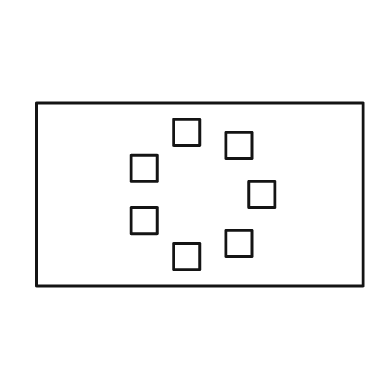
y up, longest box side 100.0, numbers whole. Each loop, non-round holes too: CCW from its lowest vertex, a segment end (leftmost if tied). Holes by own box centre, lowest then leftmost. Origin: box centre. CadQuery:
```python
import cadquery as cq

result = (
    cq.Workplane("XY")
    .moveTo(-50.0, -28.0)
    .lineTo(50.0, -28.0)
    .lineTo(50.0, 28.0)
    .lineTo(-50.0, 28.0)
    .close()
    .moveTo(-8.0, -23.0)
    .lineTo(0.0, -23.0)
    .lineTo(0.0, -15.0)
    .lineTo(-8.0, -15.0)
    .close()
    .moveTo(8.0, -19.0)
    .lineTo(16.0, -19.0)
    .lineTo(16.0, -11.0)
    .lineTo(8.0, -11.0)
    .close()
    .moveTo(-21.0, -12.0)
    .lineTo(-13.0, -12.0)
    .lineTo(-13.0, -4.0)
    .lineTo(-21.0, -4.0)
    .close()
    .moveTo(15.0, -4.0)
    .lineTo(23.0, -4.0)
    .lineTo(23.0, 4.0)
    .lineTo(15.0, 4.0)
    .close()
    .moveTo(-21.0, 4.0)
    .lineTo(-13.0, 4.0)
    .lineTo(-13.0, 12.0)
    .lineTo(-21.0, 12.0)
    .close()
    .moveTo(8.0, 11.0)
    .lineTo(16.0, 11.0)
    .lineTo(16.0, 19.0)
    .lineTo(8.0, 19.0)
    .close()
    .moveTo(-8.0, 15.0)
    .lineTo(0.0, 15.0)
    .lineTo(0.0, 23.0)
    .lineTo(-8.0, 23.0)
    .close()
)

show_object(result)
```